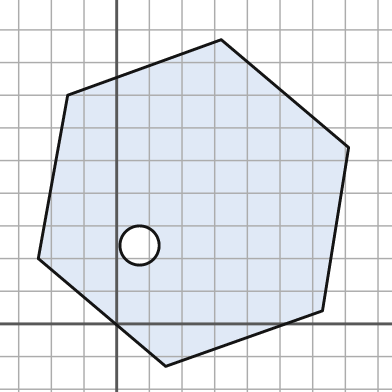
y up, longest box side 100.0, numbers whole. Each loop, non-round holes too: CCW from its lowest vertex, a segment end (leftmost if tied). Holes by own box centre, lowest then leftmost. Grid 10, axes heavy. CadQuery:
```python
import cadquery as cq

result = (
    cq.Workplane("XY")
    .moveTo(15.0, -13.0)
    .lineTo(63.0, 4.0)
    .lineTo(71.0, 54.0)
    .lineTo(32.0, 87.0)
    .lineTo(-15.0, 70.0)
    .lineTo(-24.0, 20.0)
    .close()
    .moveTo(7.0, 24.0)
    .circle(6.0)
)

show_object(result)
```